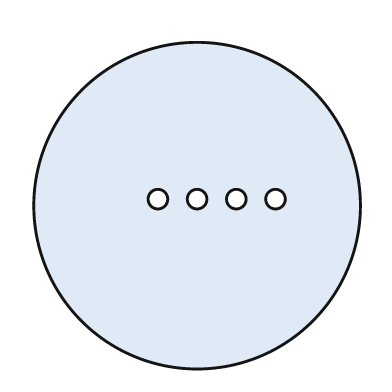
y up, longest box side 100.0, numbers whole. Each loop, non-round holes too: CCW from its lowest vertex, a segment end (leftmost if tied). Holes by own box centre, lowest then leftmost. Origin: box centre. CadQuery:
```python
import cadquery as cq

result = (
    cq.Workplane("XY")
    .moveTo(0.0, 0.0)
    .circle(50.0)
    .moveTo(-12.0, 2.0)
    .circle(3.0)
    .moveTo(0.0, 2.0)
    .circle(3.0)
    .moveTo(12.0, 2.0)
    .circle(3.0)
    .moveTo(24.0, 2.0)
    .circle(3.0)
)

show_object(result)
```